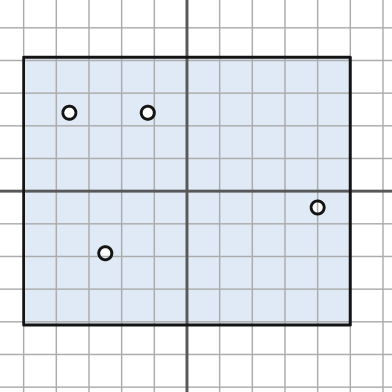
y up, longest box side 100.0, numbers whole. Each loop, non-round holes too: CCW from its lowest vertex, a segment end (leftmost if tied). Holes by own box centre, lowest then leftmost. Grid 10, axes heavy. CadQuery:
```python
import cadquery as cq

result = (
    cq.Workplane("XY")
    .moveTo(-50.0, -41.0)
    .lineTo(50.0, -41.0)
    .lineTo(50.0, 41.0)
    .lineTo(-50.0, 41.0)
    .close()
    .moveTo(-25.0, -19.0)
    .circle(2.0)
    .moveTo(40.0, -5.0)
    .circle(2.0)
    .moveTo(-36.0, 24.0)
    .circle(2.0)
    .moveTo(-12.0, 24.0)
    .circle(2.0)
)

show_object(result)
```